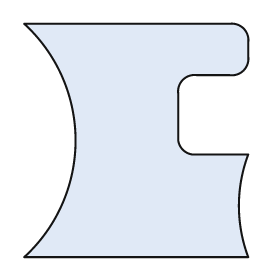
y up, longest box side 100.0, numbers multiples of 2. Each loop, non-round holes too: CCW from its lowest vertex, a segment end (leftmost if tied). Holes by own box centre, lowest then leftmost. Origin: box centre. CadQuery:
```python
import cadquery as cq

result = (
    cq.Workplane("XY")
    .moveTo(-48.0, -50.0)
    .lineTo(48.0, -50.0)
    .threePointArc((44.0, -28.0), (48.0, -6.0))
    .lineTo(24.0, -6.0)
    .threePointArc((20.0, -4.0), (18.0, 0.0))
    .lineTo(18.0, 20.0)
    .threePointArc((20.0, 26.0), (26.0, 28.0))
    .lineTo(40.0, 28.0)
    .threePointArc((46.0, 30.0), (48.0, 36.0))
    .lineTo(48.0, 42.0)
    .threePointArc((46.0, 48.0), (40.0, 50.0))
    .lineTo(-48.0, 50.0)
    .threePointArc((-26.0, 0.0), (-48.0, -50.0))
    .close()
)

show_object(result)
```